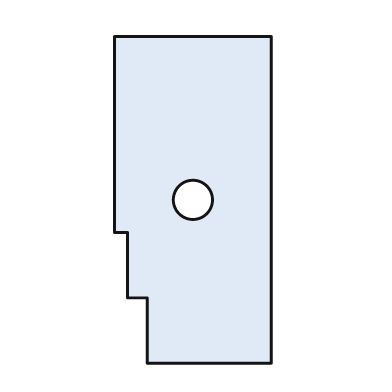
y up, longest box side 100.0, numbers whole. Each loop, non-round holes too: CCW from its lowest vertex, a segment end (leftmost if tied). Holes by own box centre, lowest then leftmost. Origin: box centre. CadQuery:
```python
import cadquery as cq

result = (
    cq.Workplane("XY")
    .moveTo(-14.0, -50.0)
    .lineTo(24.0, -50.0)
    .lineTo(24.0, 50.0)
    .lineTo(-24.0, 50.0)
    .lineTo(-24.0, -10.0)
    .lineTo(-20.0, -10.0)
    .lineTo(-20.0, -30.0)
    .lineTo(-14.0, -30.0)
    .close()
    .moveTo(0.0, 0.0)
    .circle(6.0)
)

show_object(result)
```